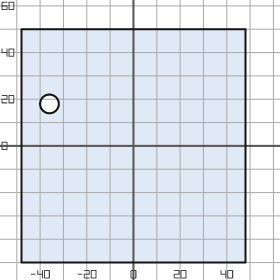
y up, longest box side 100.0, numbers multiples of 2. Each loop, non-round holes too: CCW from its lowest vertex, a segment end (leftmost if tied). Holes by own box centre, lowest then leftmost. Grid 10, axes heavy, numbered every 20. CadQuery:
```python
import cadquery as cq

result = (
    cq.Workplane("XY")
    .moveTo(-48.0, -50.0)
    .lineTo(48.0, -50.0)
    .lineTo(48.0, 50.0)
    .lineTo(-48.0, 50.0)
    .close()
    .moveTo(-36.0, 18.0)
    .circle(4.0)
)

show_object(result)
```